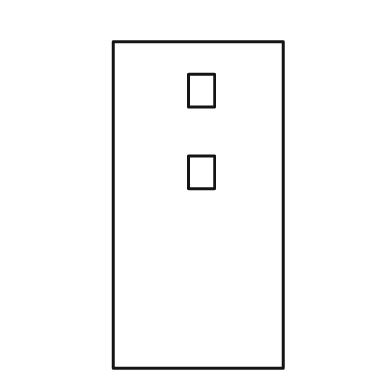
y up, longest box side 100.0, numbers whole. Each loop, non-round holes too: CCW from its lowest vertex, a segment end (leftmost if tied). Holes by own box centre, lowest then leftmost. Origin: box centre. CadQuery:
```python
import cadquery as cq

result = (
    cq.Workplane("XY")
    .moveTo(-26.0, -50.0)
    .lineTo(26.0, -50.0)
    .lineTo(26.0, 50.0)
    .lineTo(-26.0, 50.0)
    .close()
    .moveTo(-3.0, 5.0)
    .lineTo(5.0, 5.0)
    .lineTo(5.0, 15.0)
    .lineTo(-3.0, 15.0)
    .close()
    .moveTo(-3.0, 30.0)
    .lineTo(5.0, 30.0)
    .lineTo(5.0, 40.0)
    .lineTo(-3.0, 40.0)
    .close()
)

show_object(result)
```